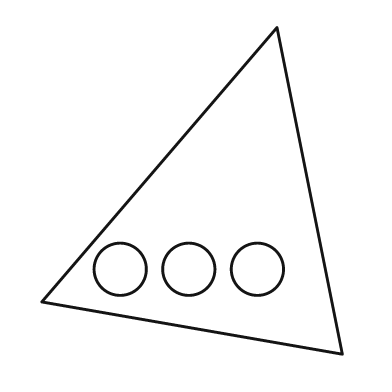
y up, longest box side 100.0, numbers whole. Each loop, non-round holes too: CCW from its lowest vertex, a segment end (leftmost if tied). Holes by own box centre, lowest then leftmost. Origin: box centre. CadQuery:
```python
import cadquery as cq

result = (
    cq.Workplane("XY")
    .moveTo(46.0, -50.0)
    .lineTo(26.0, 50.0)
    .lineTo(-46.0, -34.0)
    .close()
    .moveTo(-22.0, -24.0)
    .circle(8.0)
    .moveTo(-1.0, -24.0)
    .circle(8.0)
    .moveTo(20.0, -24.0)
    .circle(8.0)
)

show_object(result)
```